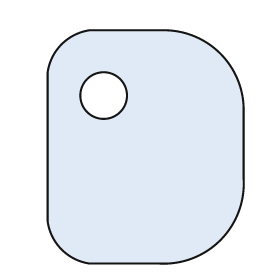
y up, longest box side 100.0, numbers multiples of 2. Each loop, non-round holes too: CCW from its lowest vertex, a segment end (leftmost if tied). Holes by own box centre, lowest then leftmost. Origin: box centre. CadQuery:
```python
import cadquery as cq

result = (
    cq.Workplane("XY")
    .moveTo(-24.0, -50.0)
    .lineTo(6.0, -50.0)
    .threePointArc((32.0, -40.0), (42.0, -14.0))
    .lineTo(42.0, 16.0)
    .threePointArc((32.0, 40.0), (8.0, 50.0))
    .lineTo(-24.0, 50.0)
    .threePointArc((-36.0, 44.0), (-42.0, 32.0))
    .lineTo(-42.0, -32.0)
    .threePointArc((-36.0, -44.0), (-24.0, -50.0))
    .close()
    .moveTo(-18.0, 22.0)
    .circle(10.0)
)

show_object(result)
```